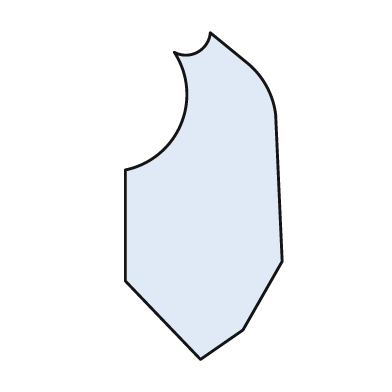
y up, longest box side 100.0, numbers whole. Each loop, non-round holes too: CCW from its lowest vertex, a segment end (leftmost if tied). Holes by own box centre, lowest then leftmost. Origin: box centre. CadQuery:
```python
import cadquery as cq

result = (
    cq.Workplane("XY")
    .moveTo(-1.0, -50.0)
    .lineTo(12.0, -41.0)
    .lineTo(24.0, -20.0)
    .lineTo(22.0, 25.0)
    .threePointArc((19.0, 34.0), (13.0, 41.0))
    .lineTo(2.0, 50.0)
    .threePointArc((-2.0, 44.0), (-9.0, 44.0))
    .threePointArc((-7.0, 22.0), (-24.0, 8.0))
    .lineTo(-24.0, -26.0)
    .close()
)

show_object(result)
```